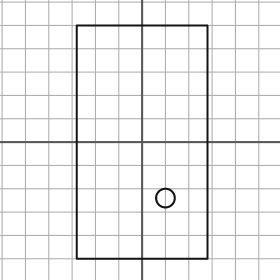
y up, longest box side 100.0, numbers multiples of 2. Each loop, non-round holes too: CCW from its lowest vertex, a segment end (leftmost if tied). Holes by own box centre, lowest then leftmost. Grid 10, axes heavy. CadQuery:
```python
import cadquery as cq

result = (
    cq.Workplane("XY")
    .moveTo(-28.0, -50.0)
    .lineTo(28.0, -50.0)
    .lineTo(28.0, 50.0)
    .lineTo(-28.0, 50.0)
    .close()
    .moveTo(10.0, -24.0)
    .circle(4.0)
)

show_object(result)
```